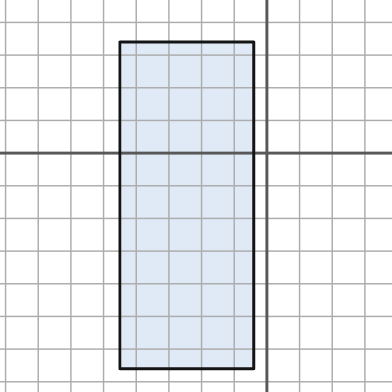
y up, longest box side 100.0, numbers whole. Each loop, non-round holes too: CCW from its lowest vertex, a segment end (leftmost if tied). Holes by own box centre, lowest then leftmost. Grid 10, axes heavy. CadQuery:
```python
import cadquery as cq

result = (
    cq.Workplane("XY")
    .moveTo(-45.0, -66.0)
    .lineTo(-4.0, -66.0)
    .lineTo(-4.0, 34.0)
    .lineTo(-45.0, 34.0)
    .close()
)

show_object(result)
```